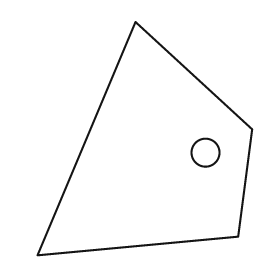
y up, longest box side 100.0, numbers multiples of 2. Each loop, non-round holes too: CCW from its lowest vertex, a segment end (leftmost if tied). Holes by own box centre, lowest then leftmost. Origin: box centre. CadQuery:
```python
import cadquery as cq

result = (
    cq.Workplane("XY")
    .moveTo(-46.0, -50.0)
    .lineTo(40.0, -42.0)
    .lineTo(46.0, 4.0)
    .lineTo(-4.0, 50.0)
    .close()
    .moveTo(26.0, -6.0)
    .circle(6.0)
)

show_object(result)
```